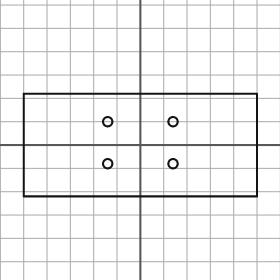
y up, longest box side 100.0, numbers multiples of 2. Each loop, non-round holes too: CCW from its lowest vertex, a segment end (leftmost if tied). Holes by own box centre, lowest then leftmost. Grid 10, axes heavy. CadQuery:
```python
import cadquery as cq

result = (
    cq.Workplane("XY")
    .moveTo(-50.0, -22.0)
    .lineTo(50.0, -22.0)
    .lineTo(50.0, 22.0)
    .lineTo(-50.0, 22.0)
    .close()
    .moveTo(-14.0, -8.0)
    .circle(2.0)
    .moveTo(14.0, -8.0)
    .circle(2.0)
    .moveTo(-14.0, 10.0)
    .circle(2.0)
    .moveTo(14.0, 10.0)
    .circle(2.0)
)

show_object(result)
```